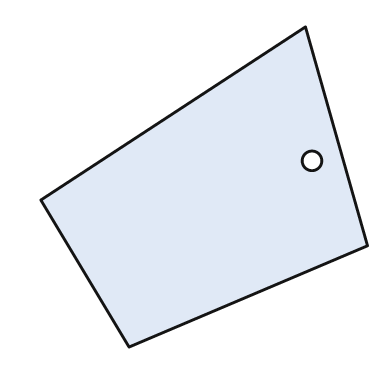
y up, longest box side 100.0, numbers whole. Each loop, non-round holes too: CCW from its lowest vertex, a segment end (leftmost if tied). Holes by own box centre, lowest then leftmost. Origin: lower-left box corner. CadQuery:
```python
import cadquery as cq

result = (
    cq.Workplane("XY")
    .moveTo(27.0, 0.0)
    .lineTo(100.0, 31.0)
    .lineTo(81.0, 98.0)
    .lineTo(0.0, 45.0)
    .close()
    .moveTo(83.0, 57.0)
    .circle(3.0)
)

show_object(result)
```